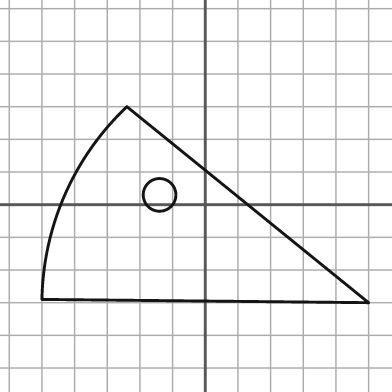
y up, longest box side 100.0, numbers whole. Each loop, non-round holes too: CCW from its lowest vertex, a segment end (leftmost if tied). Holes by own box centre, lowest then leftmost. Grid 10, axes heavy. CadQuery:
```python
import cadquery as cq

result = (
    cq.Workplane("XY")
    .moveTo(50.0, -30.0)
    .lineTo(-24.0, 30.0)
    .threePointArc((-43.0, 3.0), (-50.0, -29.0))
    .close()
    .moveTo(-14.0, 3.0)
    .circle(5.0)
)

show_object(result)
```